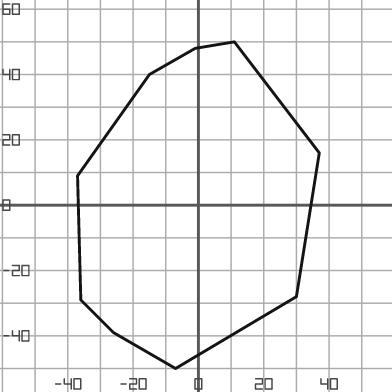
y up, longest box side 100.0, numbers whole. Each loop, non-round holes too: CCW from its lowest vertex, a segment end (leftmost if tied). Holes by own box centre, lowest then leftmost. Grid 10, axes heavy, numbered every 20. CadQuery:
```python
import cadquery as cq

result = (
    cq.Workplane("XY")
    .moveTo(-7.0, -50.0)
    .lineTo(30.0, -28.0)
    .lineTo(37.0, 16.0)
    .lineTo(11.0, 50.0)
    .lineTo(-1.0, 48.0)
    .lineTo(-15.0, 40.0)
    .lineTo(-37.0, 9.0)
    .lineTo(-36.0, -29.0)
    .lineTo(-26.0, -39.0)
    .close()
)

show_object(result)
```